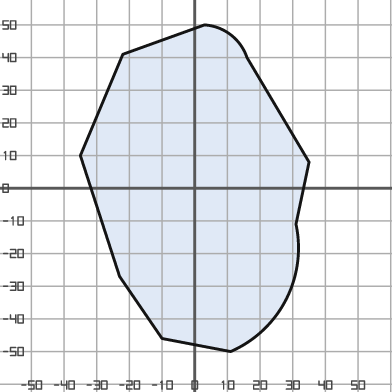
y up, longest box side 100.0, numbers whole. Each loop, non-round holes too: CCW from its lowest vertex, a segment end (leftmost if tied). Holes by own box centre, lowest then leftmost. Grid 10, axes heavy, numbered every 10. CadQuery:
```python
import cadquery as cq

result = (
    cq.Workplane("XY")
    .moveTo(11.0, -50.0)
    .threePointArc((28.0, -34.0), (31.0, -11.0))
    .lineTo(35.0, 8.0)
    .lineTo(16.0, 40.0)
    .threePointArc((11.0, 47.0), (3.0, 50.0))
    .lineTo(-22.0, 41.0)
    .lineTo(-35.0, 10.0)
    .lineTo(-23.0, -27.0)
    .lineTo(-10.0, -46.0)
    .close()
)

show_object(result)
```